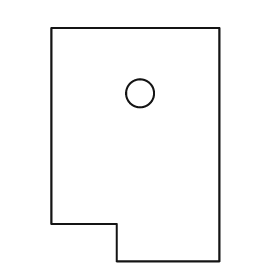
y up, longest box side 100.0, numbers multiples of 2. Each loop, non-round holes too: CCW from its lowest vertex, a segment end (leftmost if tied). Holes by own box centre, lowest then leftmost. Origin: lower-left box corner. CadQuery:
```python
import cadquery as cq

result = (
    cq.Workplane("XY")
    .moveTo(28.0, 0.0)
    .lineTo(72.0, 0.0)
    .lineTo(72.0, 100.0)
    .lineTo(0.0, 100.0)
    .lineTo(0.0, 16.0)
    .lineTo(28.0, 16.0)
    .close()
    .moveTo(38.0, 72.0)
    .circle(6.0)
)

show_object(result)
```